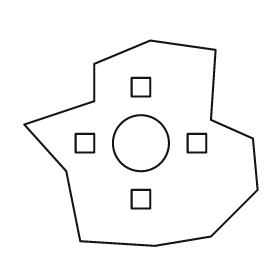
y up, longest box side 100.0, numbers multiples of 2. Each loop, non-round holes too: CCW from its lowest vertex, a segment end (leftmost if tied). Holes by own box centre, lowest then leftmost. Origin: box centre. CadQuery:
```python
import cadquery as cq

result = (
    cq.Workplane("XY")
    .moveTo(6.0, -44.0)
    .lineTo(30.0, -40.0)
    .lineTo(50.0, -20.0)
    .lineTo(48.0, 2.0)
    .lineTo(30.0, 10.0)
    .lineTo(32.0, 40.0)
    .lineTo(4.0, 44.0)
    .lineTo(-20.0, 34.0)
    .lineTo(-20.0, 18.0)
    .lineTo(-50.0, 8.0)
    .lineTo(-32.0, -12.0)
    .lineTo(-26.0, -42.0)
    .close()
    .moveTo(-4.0, -28.0)
    .lineTo(4.0, -28.0)
    .lineTo(4.0, -20.0)
    .lineTo(-4.0, -20.0)
    .close()
    .moveTo(-28.0, -4.0)
    .lineTo(-20.0, -4.0)
    .lineTo(-20.0, 4.0)
    .lineTo(-28.0, 4.0)
    .close()
    .moveTo(0.0, 0.0)
    .circle(12.0)
    .moveTo(20.0, -4.0)
    .lineTo(28.0, -4.0)
    .lineTo(28.0, 4.0)
    .lineTo(20.0, 4.0)
    .close()
    .moveTo(-4.0, 20.0)
    .lineTo(4.0, 20.0)
    .lineTo(4.0, 28.0)
    .lineTo(-4.0, 28.0)
    .close()
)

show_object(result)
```